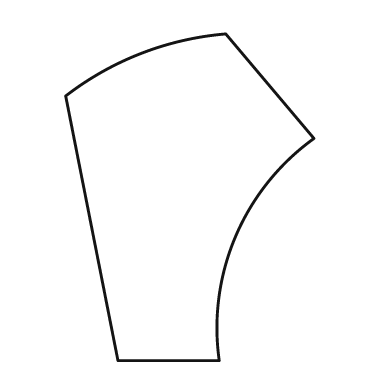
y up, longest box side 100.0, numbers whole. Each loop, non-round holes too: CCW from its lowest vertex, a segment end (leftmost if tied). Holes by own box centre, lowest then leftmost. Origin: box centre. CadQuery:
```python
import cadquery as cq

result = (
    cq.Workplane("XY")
    .moveTo(-22.0, -50.0)
    .lineTo(9.0, -50.0)
    .threePointArc((14.0, -12.0), (38.0, 18.0))
    .lineTo(11.0, 50.0)
    .threePointArc((-15.0, 44.0), (-38.0, 31.0))
    .close()
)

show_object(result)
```